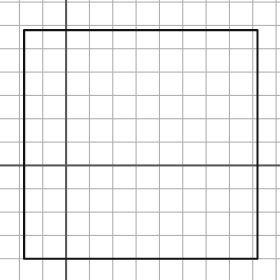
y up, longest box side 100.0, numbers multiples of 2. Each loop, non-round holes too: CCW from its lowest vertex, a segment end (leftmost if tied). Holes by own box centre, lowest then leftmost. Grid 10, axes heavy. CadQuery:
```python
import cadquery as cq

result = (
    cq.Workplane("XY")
    .moveTo(-18.0, -40.0)
    .lineTo(82.0, -40.0)
    .lineTo(82.0, 58.0)
    .lineTo(-18.0, 58.0)
    .close()
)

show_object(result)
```